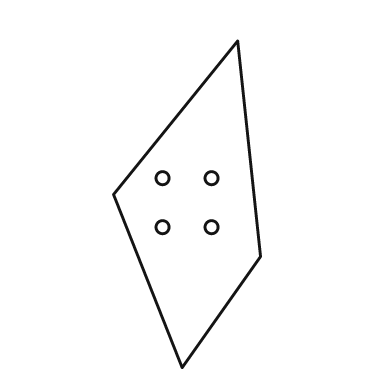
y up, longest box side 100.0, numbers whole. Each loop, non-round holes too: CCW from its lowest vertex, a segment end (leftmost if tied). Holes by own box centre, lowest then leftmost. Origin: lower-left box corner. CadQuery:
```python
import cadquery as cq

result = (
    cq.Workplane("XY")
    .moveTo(21.0, 0.0)
    .lineTo(45.0, 34.0)
    .lineTo(38.0, 100.0)
    .lineTo(0.0, 53.0)
    .close()
    .moveTo(15.0, 43.0)
    .circle(2.0)
    .moveTo(30.0, 43.0)
    .circle(2.0)
    .moveTo(15.0, 58.0)
    .circle(2.0)
    .moveTo(30.0, 58.0)
    .circle(2.0)
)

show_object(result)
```